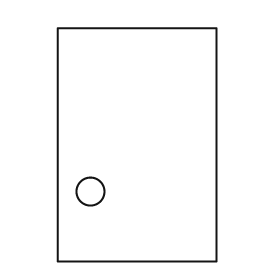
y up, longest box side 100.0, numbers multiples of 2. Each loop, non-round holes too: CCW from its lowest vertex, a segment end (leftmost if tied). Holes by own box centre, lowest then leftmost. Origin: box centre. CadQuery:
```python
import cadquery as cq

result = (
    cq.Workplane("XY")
    .moveTo(-34.0, -50.0)
    .lineTo(34.0, -50.0)
    .lineTo(34.0, 50.0)
    .lineTo(-34.0, 50.0)
    .close()
    .moveTo(-20.0, -20.0)
    .circle(6.0)
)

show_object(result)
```